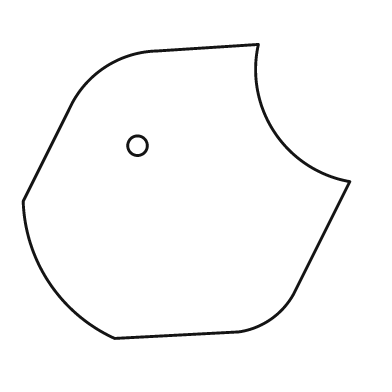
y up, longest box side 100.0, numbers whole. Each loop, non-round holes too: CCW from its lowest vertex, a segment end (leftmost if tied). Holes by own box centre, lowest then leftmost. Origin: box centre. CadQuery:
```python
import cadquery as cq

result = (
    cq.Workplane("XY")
    .moveTo(-22.0, -45.0)
    .lineTo(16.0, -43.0)
    .threePointArc((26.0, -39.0), (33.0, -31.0))
    .lineTo(50.0, 3.0)
    .threePointArc((27.0, 18.0), (22.0, 45.0))
    .lineTo(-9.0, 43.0)
    .threePointArc((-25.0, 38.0), (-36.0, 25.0))
    .lineTo(-50.0, -3.0)
    .threePointArc((-42.0, -28.0), (-22.0, -45.0))
    .close()
    .moveTo(-15.0, 14.0)
    .circle(3.0)
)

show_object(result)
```